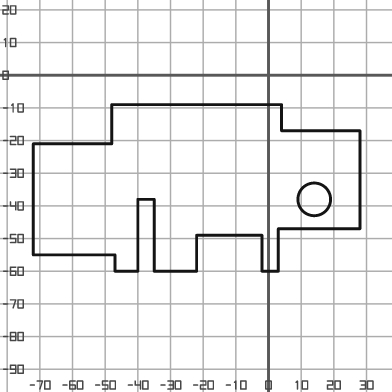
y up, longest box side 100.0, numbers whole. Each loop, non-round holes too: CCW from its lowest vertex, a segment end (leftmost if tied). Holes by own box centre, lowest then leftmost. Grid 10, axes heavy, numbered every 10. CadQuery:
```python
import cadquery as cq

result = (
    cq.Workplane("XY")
    .moveTo(-47.0, -60.0)
    .lineTo(-40.0, -60.0)
    .lineTo(-40.0, -38.0)
    .lineTo(-35.0, -38.0)
    .lineTo(-35.0, -60.0)
    .lineTo(-22.0, -60.0)
    .lineTo(-22.0, -49.0)
    .lineTo(-2.0, -49.0)
    .lineTo(-2.0, -60.0)
    .lineTo(3.0, -60.0)
    .lineTo(3.0, -47.0)
    .lineTo(28.0, -47.0)
    .lineTo(28.0, -17.0)
    .lineTo(4.0, -17.0)
    .lineTo(4.0, -9.0)
    .lineTo(-48.0, -9.0)
    .lineTo(-48.0, -21.0)
    .lineTo(-72.0, -21.0)
    .lineTo(-72.0, -55.0)
    .lineTo(-47.0, -55.0)
    .close()
    .moveTo(14.0, -38.0)
    .circle(5.0)
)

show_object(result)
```